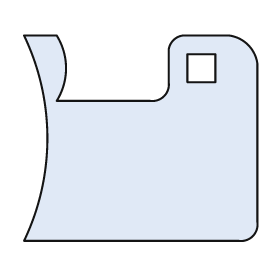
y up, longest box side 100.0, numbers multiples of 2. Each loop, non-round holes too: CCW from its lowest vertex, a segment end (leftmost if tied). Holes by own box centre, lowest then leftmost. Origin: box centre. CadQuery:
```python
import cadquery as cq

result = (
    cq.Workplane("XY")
    .moveTo(-50.0, -44.0)
    .lineTo(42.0, -44.0)
    .threePointArc((48.0, -42.0), (50.0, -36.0))
    .lineTo(50.0, 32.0)
    .threePointArc((46.0, 40.0), (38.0, 44.0))
    .lineTo(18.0, 44.0)
    .threePointArc((14.0, 42.0), (12.0, 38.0))
    .lineTo(12.0, 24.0)
    .threePointArc((10.0, 18.0), (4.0, 16.0))
    .lineTo(-36.0, 16.0)
    .threePointArc((-32.0, 30.0), (-36.0, 44.0))
    .lineTo(-50.0, 44.0)
    .threePointArc((-40.0, 0.0), (-50.0, -44.0))
    .close()
    .moveTo(20.0, 24.0)
    .lineTo(32.0, 24.0)
    .lineTo(32.0, 36.0)
    .lineTo(20.0, 36.0)
    .close()
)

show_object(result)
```